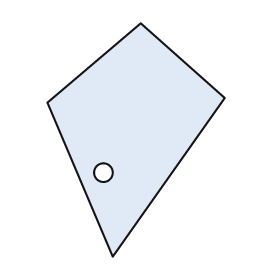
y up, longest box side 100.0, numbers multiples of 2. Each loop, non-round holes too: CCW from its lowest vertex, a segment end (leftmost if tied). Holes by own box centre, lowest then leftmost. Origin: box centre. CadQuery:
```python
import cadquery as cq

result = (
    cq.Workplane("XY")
    .moveTo(-10.0, -50.0)
    .lineTo(38.0, 18.0)
    .lineTo(2.0, 50.0)
    .lineTo(-38.0, 16.0)
    .close()
    .moveTo(-14.0, -14.0)
    .circle(4.0)
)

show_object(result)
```